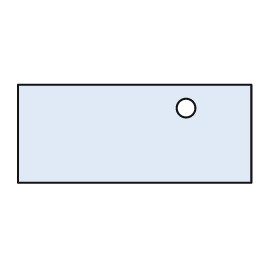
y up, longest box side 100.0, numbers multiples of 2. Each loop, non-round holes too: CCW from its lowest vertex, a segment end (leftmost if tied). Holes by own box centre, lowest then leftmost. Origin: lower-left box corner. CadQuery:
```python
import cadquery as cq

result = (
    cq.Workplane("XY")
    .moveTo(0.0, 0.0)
    .lineTo(100.0, 0.0)
    .lineTo(100.0, 42.0)
    .lineTo(0.0, 42.0)
    .close()
    .moveTo(72.0, 32.0)
    .circle(4.0)
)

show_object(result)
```